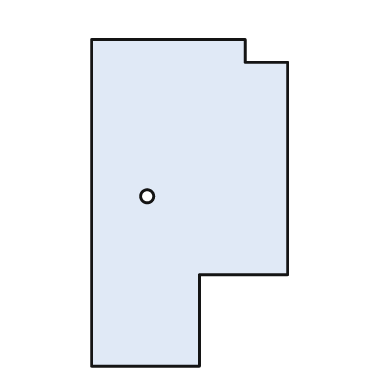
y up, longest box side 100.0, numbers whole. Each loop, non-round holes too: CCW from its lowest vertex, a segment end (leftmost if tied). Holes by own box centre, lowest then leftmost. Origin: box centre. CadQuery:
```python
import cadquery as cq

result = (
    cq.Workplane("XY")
    .moveTo(-30.0, -50.0)
    .lineTo(3.0, -50.0)
    .lineTo(3.0, -22.0)
    .lineTo(30.0, -22.0)
    .lineTo(30.0, 43.0)
    .lineTo(17.0, 43.0)
    .lineTo(17.0, 50.0)
    .lineTo(-30.0, 50.0)
    .close()
    .moveTo(-13.0, 2.0)
    .circle(2.0)
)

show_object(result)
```